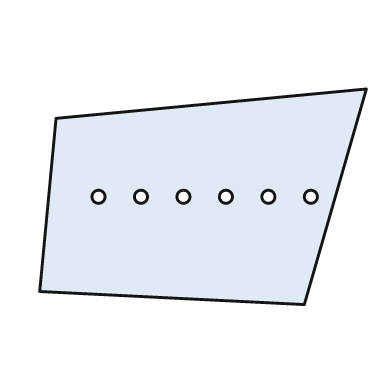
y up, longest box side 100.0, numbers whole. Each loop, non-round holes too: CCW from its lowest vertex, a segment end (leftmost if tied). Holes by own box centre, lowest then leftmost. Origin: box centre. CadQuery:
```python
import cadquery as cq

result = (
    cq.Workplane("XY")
    .moveTo(31.0, -33.0)
    .lineTo(50.0, 33.0)
    .lineTo(-45.0, 24.0)
    .lineTo(-50.0, -29.0)
    .close()
    .moveTo(-32.0, 0.0)
    .circle(2.0)
    .moveTo(-19.0, 0.0)
    .circle(2.0)
    .moveTo(-6.0, 0.0)
    .circle(2.0)
    .moveTo(7.0, 0.0)
    .circle(2.0)
    .moveTo(20.0, 0.0)
    .circle(2.0)
    .moveTo(33.0, 0.0)
    .circle(2.0)
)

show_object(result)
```